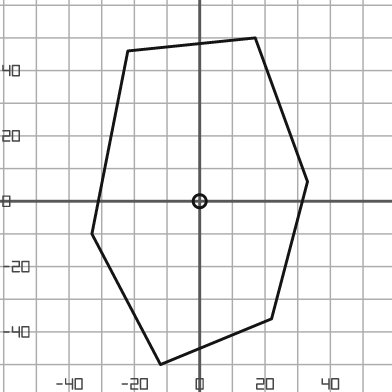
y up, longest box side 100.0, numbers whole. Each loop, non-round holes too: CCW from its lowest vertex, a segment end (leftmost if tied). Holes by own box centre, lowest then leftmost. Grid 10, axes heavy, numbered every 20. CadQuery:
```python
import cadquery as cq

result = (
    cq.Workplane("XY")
    .moveTo(-12.0, -50.0)
    .lineTo(22.0, -36.0)
    .lineTo(33.0, 6.0)
    .lineTo(17.0, 50.0)
    .lineTo(-22.0, 46.0)
    .lineTo(-33.0, -10.0)
    .close()
    .moveTo(0.0, 0.0)
    .circle(2.0)
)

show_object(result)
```